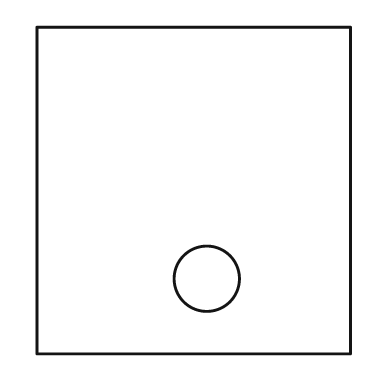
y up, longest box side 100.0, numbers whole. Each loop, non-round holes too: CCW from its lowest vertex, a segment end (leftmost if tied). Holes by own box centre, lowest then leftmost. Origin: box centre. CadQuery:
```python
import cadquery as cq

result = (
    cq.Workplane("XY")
    .moveTo(-48.0, -50.0)
    .lineTo(48.0, -50.0)
    .lineTo(48.0, 50.0)
    .lineTo(-48.0, 50.0)
    .close()
    .moveTo(4.0, -27.0)
    .circle(10.0)
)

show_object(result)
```